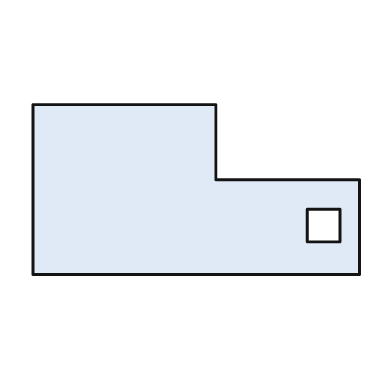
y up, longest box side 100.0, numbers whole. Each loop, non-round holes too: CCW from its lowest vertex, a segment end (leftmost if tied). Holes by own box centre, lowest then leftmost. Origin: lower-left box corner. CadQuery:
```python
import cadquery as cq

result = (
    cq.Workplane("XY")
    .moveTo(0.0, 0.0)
    .lineTo(100.0, 0.0)
    .lineTo(100.0, 29.0)
    .lineTo(56.0, 29.0)
    .lineTo(56.0, 52.0)
    .lineTo(0.0, 52.0)
    .close()
    .moveTo(84.0, 10.0)
    .lineTo(94.0, 10.0)
    .lineTo(94.0, 20.0)
    .lineTo(84.0, 20.0)
    .close()
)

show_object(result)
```